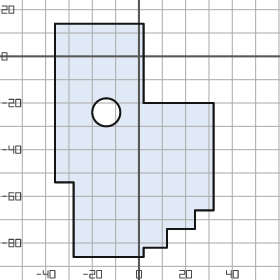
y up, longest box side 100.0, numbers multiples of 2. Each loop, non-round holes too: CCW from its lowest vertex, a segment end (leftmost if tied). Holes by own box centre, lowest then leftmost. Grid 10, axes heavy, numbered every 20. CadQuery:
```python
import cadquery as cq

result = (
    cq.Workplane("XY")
    .moveTo(-28.0, -86.0)
    .lineTo(2.0, -86.0)
    .lineTo(2.0, -82.0)
    .lineTo(12.0, -82.0)
    .lineTo(12.0, -74.0)
    .lineTo(24.0, -74.0)
    .lineTo(24.0, -66.0)
    .lineTo(32.0, -66.0)
    .lineTo(32.0, -20.0)
    .lineTo(2.0, -20.0)
    .lineTo(2.0, 14.0)
    .lineTo(-36.0, 14.0)
    .lineTo(-36.0, -54.0)
    .lineTo(-28.0, -54.0)
    .close()
    .moveTo(-14.0, -24.0)
    .circle(6.0)
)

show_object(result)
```